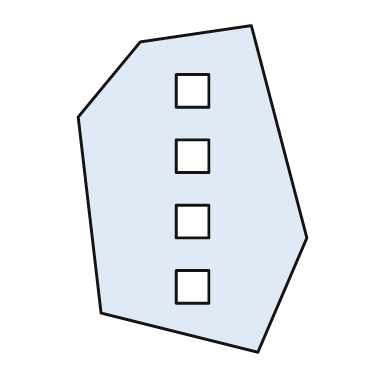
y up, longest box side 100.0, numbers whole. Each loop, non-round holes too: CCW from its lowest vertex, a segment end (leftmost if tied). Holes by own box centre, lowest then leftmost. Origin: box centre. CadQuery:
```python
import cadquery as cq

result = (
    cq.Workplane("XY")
    .moveTo(20.0, -50.0)
    .lineTo(35.0, -15.0)
    .lineTo(18.0, 50.0)
    .lineTo(-16.0, 45.0)
    .lineTo(-35.0, 22.0)
    .lineTo(-28.0, -38.0)
    .close()
    .moveTo(-5.0, -35.0)
    .lineTo(5.0, -35.0)
    .lineTo(5.0, -25.0)
    .lineTo(-5.0, -25.0)
    .close()
    .moveTo(-5.0, -15.0)
    .lineTo(5.0, -15.0)
    .lineTo(5.0, -5.0)
    .lineTo(-5.0, -5.0)
    .close()
    .moveTo(-5.0, 5.0)
    .lineTo(5.0, 5.0)
    .lineTo(5.0, 15.0)
    .lineTo(-5.0, 15.0)
    .close()
    .moveTo(-5.0, 25.0)
    .lineTo(5.0, 25.0)
    .lineTo(5.0, 35.0)
    .lineTo(-5.0, 35.0)
    .close()
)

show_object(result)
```